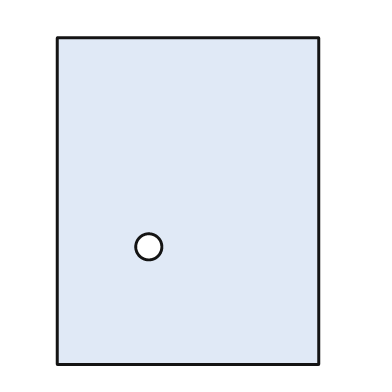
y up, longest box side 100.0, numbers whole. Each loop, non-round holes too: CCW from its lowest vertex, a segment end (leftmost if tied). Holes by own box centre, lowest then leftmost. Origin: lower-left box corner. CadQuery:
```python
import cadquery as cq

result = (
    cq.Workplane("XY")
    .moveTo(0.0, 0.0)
    .lineTo(80.0, 0.0)
    .lineTo(80.0, 100.0)
    .lineTo(0.0, 100.0)
    .close()
    .moveTo(28.0, 36.0)
    .circle(4.0)
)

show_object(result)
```